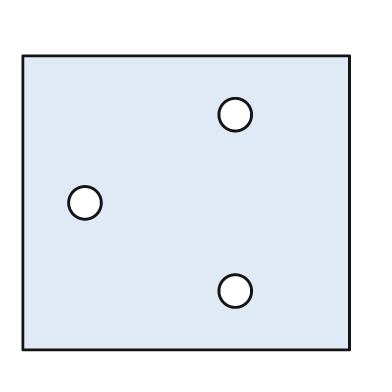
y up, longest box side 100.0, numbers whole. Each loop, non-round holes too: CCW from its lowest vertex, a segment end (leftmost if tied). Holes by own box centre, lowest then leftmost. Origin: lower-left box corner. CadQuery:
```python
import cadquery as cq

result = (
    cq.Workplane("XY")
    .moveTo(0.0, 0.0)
    .lineTo(100.0, 0.0)
    .lineTo(100.0, 90.0)
    .lineTo(0.0, 90.0)
    .close()
    .moveTo(65.0, 18.0)
    .circle(5.0)
    .moveTo(19.0, 45.0)
    .circle(5.0)
    .moveTo(65.0, 72.0)
    .circle(5.0)
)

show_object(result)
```